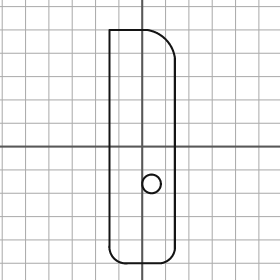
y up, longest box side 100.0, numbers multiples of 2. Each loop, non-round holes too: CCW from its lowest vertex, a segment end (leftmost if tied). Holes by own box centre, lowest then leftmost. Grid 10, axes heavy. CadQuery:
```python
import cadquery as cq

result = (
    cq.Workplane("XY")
    .moveTo(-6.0, -50.0)
    .lineTo(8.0, -50.0)
    .threePointArc((12.0, -48.0), (14.0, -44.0))
    .lineTo(14.0, 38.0)
    .threePointArc((10.0, 46.0), (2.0, 50.0))
    .lineTo(-14.0, 50.0)
    .lineTo(-14.0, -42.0)
    .threePointArc((-12.0, -48.0), (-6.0, -50.0))
    .close()
    .moveTo(4.0, -16.0)
    .circle(4.0)
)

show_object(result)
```